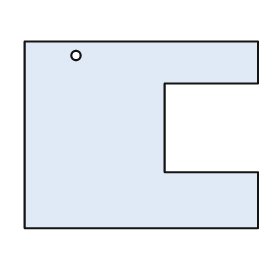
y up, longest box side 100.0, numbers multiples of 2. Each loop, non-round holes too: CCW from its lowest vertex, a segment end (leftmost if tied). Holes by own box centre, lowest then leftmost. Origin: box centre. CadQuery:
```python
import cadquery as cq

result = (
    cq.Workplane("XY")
    .moveTo(-50.0, -40.0)
    .lineTo(50.0, -40.0)
    .lineTo(50.0, -16.0)
    .lineTo(10.0, -16.0)
    .lineTo(10.0, 22.0)
    .lineTo(50.0, 22.0)
    .lineTo(50.0, 40.0)
    .lineTo(-50.0, 40.0)
    .close()
    .moveTo(-28.0, 34.0)
    .circle(2.0)
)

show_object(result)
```